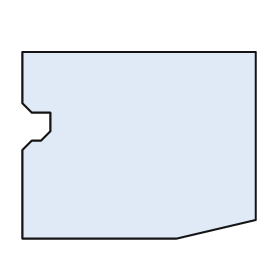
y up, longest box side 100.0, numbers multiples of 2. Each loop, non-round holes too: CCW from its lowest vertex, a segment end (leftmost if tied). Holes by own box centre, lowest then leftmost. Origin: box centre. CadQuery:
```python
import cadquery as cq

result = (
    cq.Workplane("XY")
    .moveTo(-50.0, -40.0)
    .lineTo(16.0, -40.0)
    .lineTo(50.0, -32.0)
    .lineTo(50.0, 40.0)
    .lineTo(-50.0, 40.0)
    .lineTo(-50.0, 18.0)
    .lineTo(-46.0, 14.0)
    .lineTo(-38.0, 14.0)
    .lineTo(-38.0, 6.0)
    .lineTo(-42.0, 2.0)
    .lineTo(-46.0, 2.0)
    .lineTo(-50.0, -2.0)
    .close()
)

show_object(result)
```